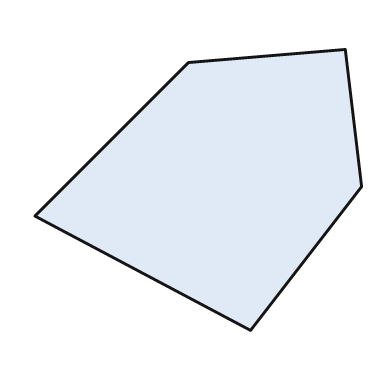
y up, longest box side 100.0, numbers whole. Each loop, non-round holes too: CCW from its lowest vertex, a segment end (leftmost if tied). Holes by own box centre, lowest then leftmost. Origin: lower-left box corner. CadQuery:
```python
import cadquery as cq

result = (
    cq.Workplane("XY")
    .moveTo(66.0, 0.0)
    .lineTo(100.0, 44.0)
    .lineTo(95.0, 86.0)
    .lineTo(47.0, 82.0)
    .lineTo(0.0, 35.0)
    .close()
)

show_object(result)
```